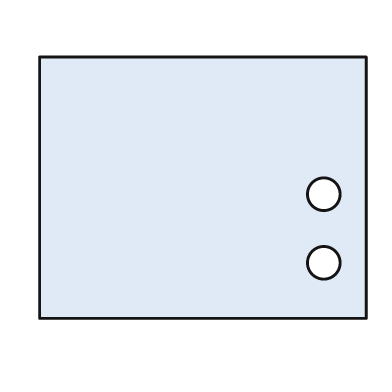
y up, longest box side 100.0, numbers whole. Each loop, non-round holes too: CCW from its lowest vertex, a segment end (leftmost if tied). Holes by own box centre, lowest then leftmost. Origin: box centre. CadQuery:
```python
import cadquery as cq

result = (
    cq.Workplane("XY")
    .moveTo(-50.0, -40.0)
    .lineTo(50.0, -40.0)
    .lineTo(50.0, 40.0)
    .lineTo(-50.0, 40.0)
    .close()
    .moveTo(37.0, -23.0)
    .circle(5.0)
    .moveTo(37.0, -2.0)
    .circle(5.0)
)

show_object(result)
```